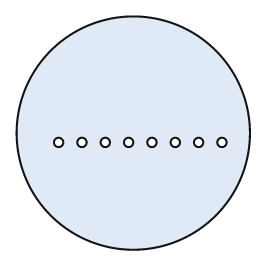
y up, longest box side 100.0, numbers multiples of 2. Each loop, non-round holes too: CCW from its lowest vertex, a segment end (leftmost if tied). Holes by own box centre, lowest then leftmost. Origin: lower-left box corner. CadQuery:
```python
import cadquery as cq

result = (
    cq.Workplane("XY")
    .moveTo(50.0, 50.0)
    .circle(50.0)
    .moveTo(18.0, 46.0)
    .circle(2.0)
    .moveTo(28.0, 46.0)
    .circle(2.0)
    .moveTo(38.0, 46.0)
    .circle(2.0)
    .moveTo(48.0, 46.0)
    .circle(2.0)
    .moveTo(58.0, 46.0)
    .circle(2.0)
    .moveTo(68.0, 46.0)
    .circle(2.0)
    .moveTo(78.0, 46.0)
    .circle(2.0)
    .moveTo(88.0, 46.0)
    .circle(2.0)
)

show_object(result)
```